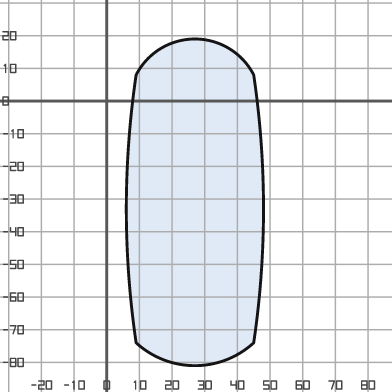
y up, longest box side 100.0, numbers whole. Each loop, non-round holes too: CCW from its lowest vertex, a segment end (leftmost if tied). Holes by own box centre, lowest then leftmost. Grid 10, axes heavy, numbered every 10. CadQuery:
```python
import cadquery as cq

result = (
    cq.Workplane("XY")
    .moveTo(9.0, -74.0)
    .threePointArc((27.0, -81.0), (45.0, -74.0))
    .threePointArc((48.0, -33.0), (45.0, 8.0))
    .threePointArc((27.0, 19.0), (9.0, 8.0))
    .threePointArc((6.0, -33.0), (9.0, -74.0))
    .close()
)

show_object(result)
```